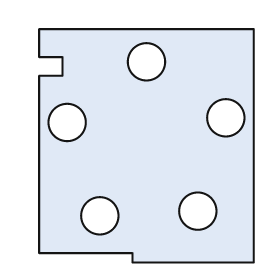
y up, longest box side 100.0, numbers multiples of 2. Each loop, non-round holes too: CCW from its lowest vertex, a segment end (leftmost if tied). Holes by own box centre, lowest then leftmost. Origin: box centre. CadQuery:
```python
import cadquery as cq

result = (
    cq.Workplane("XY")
    .moveTo(-6.0, -50.0)
    .lineTo(46.0, -50.0)
    .lineTo(46.0, 50.0)
    .lineTo(-46.0, 50.0)
    .lineTo(-46.0, 38.0)
    .lineTo(-36.0, 38.0)
    .lineTo(-36.0, 30.0)
    .lineTo(-46.0, 30.0)
    .lineTo(-46.0, -46.0)
    .lineTo(-6.0, -46.0)
    .close()
    .moveTo(-20.0, -30.0)
    .circle(8.0)
    .moveTo(22.0, -28.0)
    .circle(8.0)
    .moveTo(-34.0, 10.0)
    .circle(8.0)
    .moveTo(34.0, 12.0)
    .circle(8.0)
    .moveTo(0.0, 36.0)
    .circle(8.0)
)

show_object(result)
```